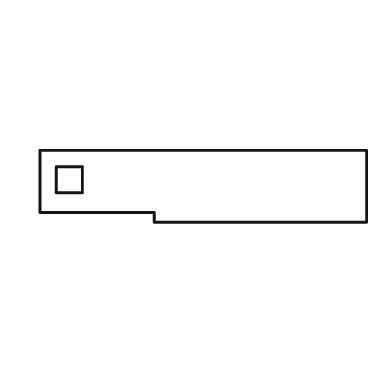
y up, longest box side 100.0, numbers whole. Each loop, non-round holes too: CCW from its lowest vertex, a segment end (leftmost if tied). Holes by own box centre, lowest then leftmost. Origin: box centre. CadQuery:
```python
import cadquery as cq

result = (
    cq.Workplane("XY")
    .moveTo(-15.0, -11.0)
    .lineTo(50.0, -11.0)
    .lineTo(50.0, 11.0)
    .lineTo(-50.0, 11.0)
    .lineTo(-50.0, -8.0)
    .lineTo(-15.0, -8.0)
    .close()
    .moveTo(-45.0, -2.0)
    .lineTo(-37.0, -2.0)
    .lineTo(-37.0, 6.0)
    .lineTo(-45.0, 6.0)
    .close()
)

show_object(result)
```